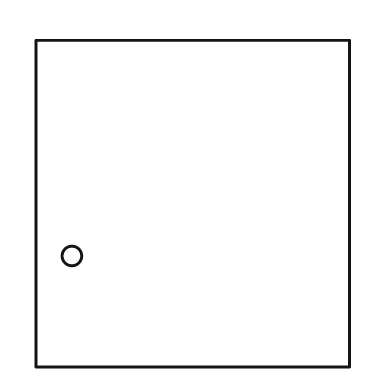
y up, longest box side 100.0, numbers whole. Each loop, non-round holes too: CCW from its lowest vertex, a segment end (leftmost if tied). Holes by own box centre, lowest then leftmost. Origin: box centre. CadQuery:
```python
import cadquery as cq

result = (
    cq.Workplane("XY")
    .moveTo(-48.0, -50.0)
    .lineTo(48.0, -50.0)
    .lineTo(48.0, 50.0)
    .lineTo(-48.0, 50.0)
    .close()
    .moveTo(-37.0, -16.0)
    .circle(3.0)
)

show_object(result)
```